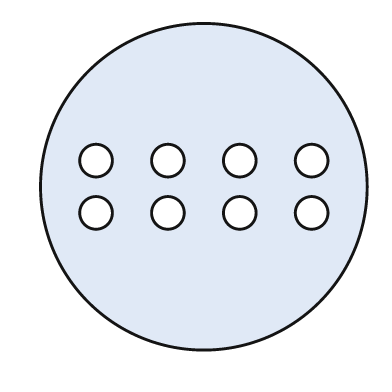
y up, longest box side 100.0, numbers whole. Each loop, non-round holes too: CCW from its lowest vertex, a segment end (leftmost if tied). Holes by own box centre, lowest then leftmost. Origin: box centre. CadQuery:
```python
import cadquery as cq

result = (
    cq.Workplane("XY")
    .moveTo(0.0, 0.0)
    .circle(50.0)
    .moveTo(-33.0, -8.0)
    .circle(5.0)
    .moveTo(-11.0, -8.0)
    .circle(5.0)
    .moveTo(11.0, -8.0)
    .circle(5.0)
    .moveTo(33.0, -8.0)
    .circle(5.0)
    .moveTo(-33.0, 8.0)
    .circle(5.0)
    .moveTo(-11.0, 8.0)
    .circle(5.0)
    .moveTo(11.0, 8.0)
    .circle(5.0)
    .moveTo(33.0, 8.0)
    .circle(5.0)
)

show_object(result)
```